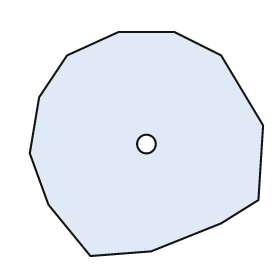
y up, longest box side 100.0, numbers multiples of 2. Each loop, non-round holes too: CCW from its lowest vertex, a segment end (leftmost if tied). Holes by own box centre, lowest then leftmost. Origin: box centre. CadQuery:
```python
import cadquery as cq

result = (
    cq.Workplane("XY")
    .moveTo(-24.0, -48.0)
    .lineTo(2.0, -46.0)
    .lineTo(32.0, -34.0)
    .lineTo(48.0, -24.0)
    .lineTo(50.0, 8.0)
    .lineTo(32.0, 38.0)
    .lineTo(12.0, 48.0)
    .lineTo(-12.0, 48.0)
    .lineTo(-34.0, 38.0)
    .lineTo(-46.0, 20.0)
    .lineTo(-50.0, -4.0)
    .lineTo(-42.0, -26.0)
    .close()
    .moveTo(0.0, 0.0)
    .circle(4.0)
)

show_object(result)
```